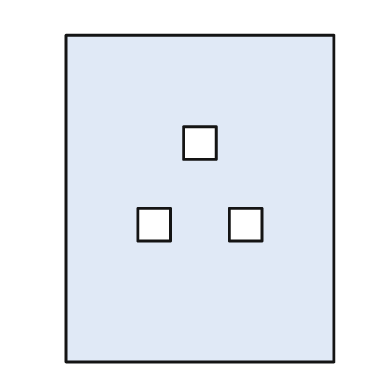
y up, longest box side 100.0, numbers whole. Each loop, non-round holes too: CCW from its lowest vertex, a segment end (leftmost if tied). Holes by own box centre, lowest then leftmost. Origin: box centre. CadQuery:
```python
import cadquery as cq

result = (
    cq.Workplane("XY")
    .moveTo(-41.0, -50.0)
    .lineTo(41.0, -50.0)
    .lineTo(41.0, 50.0)
    .lineTo(-41.0, 50.0)
    .close()
    .moveTo(-19.0, -13.0)
    .lineTo(-9.0, -13.0)
    .lineTo(-9.0, -3.0)
    .lineTo(-19.0, -3.0)
    .close()
    .moveTo(9.0, -13.0)
    .lineTo(19.0, -13.0)
    .lineTo(19.0, -3.0)
    .lineTo(9.0, -3.0)
    .close()
    .moveTo(-5.0, 12.0)
    .lineTo(5.0, 12.0)
    .lineTo(5.0, 22.0)
    .lineTo(-5.0, 22.0)
    .close()
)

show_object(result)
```